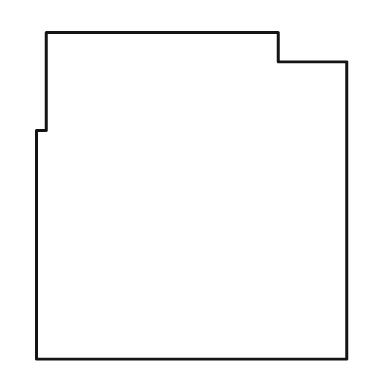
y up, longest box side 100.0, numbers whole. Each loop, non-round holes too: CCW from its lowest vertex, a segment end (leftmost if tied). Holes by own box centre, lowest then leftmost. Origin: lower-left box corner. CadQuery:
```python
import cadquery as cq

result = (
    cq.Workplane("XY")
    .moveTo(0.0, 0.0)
    .lineTo(95.0, 0.0)
    .lineTo(95.0, 91.0)
    .lineTo(74.0, 91.0)
    .lineTo(74.0, 100.0)
    .lineTo(3.0, 100.0)
    .lineTo(3.0, 70.0)
    .lineTo(0.0, 70.0)
    .close()
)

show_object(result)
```